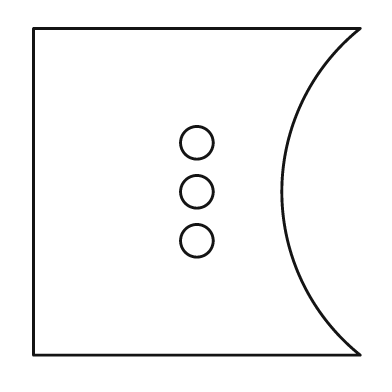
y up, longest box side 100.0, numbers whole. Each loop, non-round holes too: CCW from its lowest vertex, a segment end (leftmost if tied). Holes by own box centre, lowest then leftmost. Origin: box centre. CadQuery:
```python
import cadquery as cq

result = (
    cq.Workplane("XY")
    .moveTo(-50.0, -50.0)
    .lineTo(50.0, -50.0)
    .threePointArc((26.0, 0.0), (50.0, 50.0))
    .lineTo(-50.0, 50.0)
    .close()
    .moveTo(0.0, -15.0)
    .circle(5.0)
    .moveTo(0.0, 0.0)
    .circle(5.0)
    .moveTo(0.0, 15.0)
    .circle(5.0)
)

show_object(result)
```